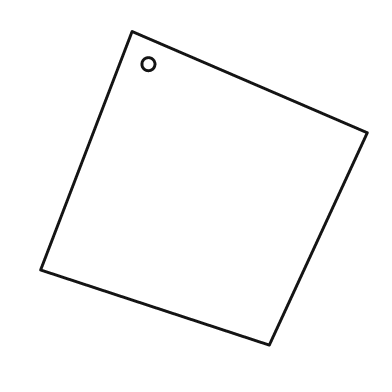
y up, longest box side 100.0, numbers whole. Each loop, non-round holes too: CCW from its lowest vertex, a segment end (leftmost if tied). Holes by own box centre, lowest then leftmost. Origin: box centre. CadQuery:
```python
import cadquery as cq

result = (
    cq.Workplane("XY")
    .moveTo(20.0, -48.0)
    .lineTo(50.0, 17.0)
    .lineTo(-22.0, 48.0)
    .lineTo(-50.0, -25.0)
    .close()
    .moveTo(-17.0, 38.0)
    .circle(2.0)
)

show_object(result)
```